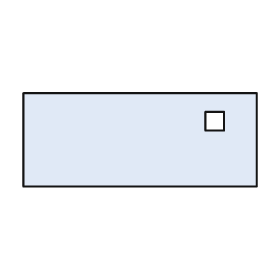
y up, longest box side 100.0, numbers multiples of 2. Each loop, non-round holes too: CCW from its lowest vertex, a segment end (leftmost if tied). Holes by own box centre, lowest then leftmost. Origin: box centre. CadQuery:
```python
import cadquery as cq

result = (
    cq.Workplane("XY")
    .moveTo(-50.0, -20.0)
    .lineTo(50.0, -20.0)
    .lineTo(50.0, 20.0)
    .lineTo(-50.0, 20.0)
    .close()
    .moveTo(28.0, 4.0)
    .lineTo(36.0, 4.0)
    .lineTo(36.0, 12.0)
    .lineTo(28.0, 12.0)
    .close()
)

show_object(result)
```